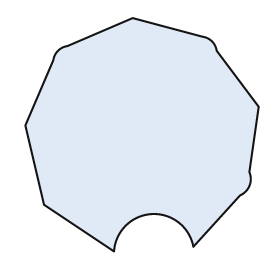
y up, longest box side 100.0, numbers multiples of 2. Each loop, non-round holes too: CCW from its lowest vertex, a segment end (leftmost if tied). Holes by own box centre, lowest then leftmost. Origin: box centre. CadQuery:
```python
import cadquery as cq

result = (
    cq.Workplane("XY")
    .moveTo(-12.0, -50.0)
    .threePointArc((4.0, -34.0), (22.0, -48.0))
    .lineTo(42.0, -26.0)
    .threePointArc((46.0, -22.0), (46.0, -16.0))
    .lineTo(50.0, 12.0)
    .lineTo(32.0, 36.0)
    .threePointArc((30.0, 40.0), (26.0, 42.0))
    .lineTo(-4.0, 50.0)
    .lineTo(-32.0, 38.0)
    .threePointArc((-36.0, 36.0), (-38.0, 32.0))
    .lineTo(-50.0, 4.0)
    .lineTo(-42.0, -30.0)
    .close()
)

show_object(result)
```